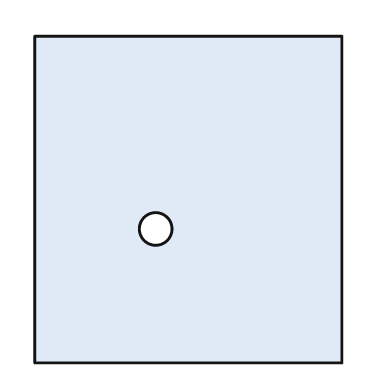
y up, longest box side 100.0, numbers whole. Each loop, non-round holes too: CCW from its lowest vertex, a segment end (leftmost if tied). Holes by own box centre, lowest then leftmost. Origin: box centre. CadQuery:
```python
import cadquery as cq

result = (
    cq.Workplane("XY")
    .moveTo(-47.0, -50.0)
    .lineTo(47.0, -50.0)
    .lineTo(47.0, 50.0)
    .lineTo(-47.0, 50.0)
    .close()
    .moveTo(-10.0, -9.0)
    .circle(5.0)
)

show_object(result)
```